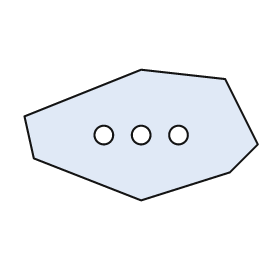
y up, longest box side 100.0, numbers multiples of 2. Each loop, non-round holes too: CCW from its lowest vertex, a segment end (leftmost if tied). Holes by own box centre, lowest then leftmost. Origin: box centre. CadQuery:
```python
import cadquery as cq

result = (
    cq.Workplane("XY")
    .moveTo(0.0, -28.0)
    .lineTo(38.0, -16.0)
    .lineTo(50.0, -4.0)
    .lineTo(36.0, 24.0)
    .lineTo(0.0, 28.0)
    .lineTo(-50.0, 8.0)
    .lineTo(-46.0, -10.0)
    .close()
    .moveTo(-16.0, 0.0)
    .circle(4.0)
    .moveTo(0.0, 0.0)
    .circle(4.0)
    .moveTo(16.0, 0.0)
    .circle(4.0)
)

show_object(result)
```